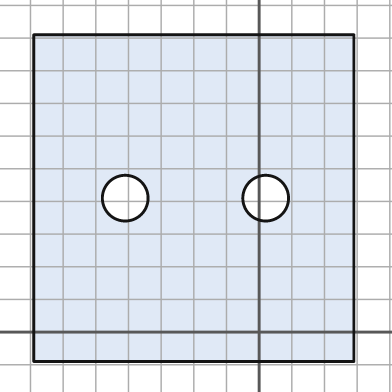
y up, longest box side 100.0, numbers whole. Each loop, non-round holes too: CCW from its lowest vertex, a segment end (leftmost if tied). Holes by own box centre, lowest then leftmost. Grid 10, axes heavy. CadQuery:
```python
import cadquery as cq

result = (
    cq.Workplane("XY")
    .moveTo(-69.0, -9.0)
    .lineTo(29.0, -9.0)
    .lineTo(29.0, 91.0)
    .lineTo(-69.0, 91.0)
    .close()
    .moveTo(-41.0, 41.0)
    .circle(7.0)
    .moveTo(2.0, 41.0)
    .circle(7.0)
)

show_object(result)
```